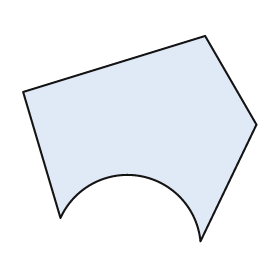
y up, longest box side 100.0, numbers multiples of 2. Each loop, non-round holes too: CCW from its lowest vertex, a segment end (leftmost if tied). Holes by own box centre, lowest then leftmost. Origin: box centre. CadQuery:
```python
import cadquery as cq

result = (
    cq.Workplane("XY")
    .moveTo(26.0, -44.0)
    .lineTo(50.0, 6.0)
    .lineTo(28.0, 44.0)
    .lineTo(-50.0, 20.0)
    .lineTo(-34.0, -34.0)
    .threePointArc((0.0, -16.0), (26.0, -44.0))
    .close()
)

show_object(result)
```